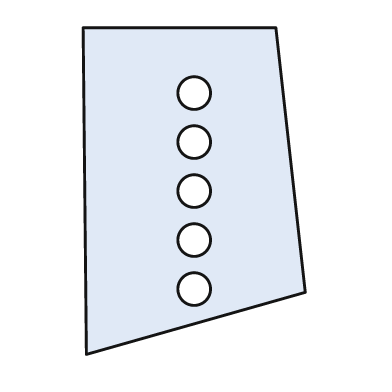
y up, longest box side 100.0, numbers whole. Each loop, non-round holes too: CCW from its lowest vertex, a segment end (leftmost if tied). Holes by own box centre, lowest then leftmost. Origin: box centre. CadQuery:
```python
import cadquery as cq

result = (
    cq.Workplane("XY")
    .moveTo(-33.0, -50.0)
    .lineTo(34.0, -31.0)
    .lineTo(25.0, 50.0)
    .lineTo(-34.0, 50.0)
    .close()
    .moveTo(0.0, -30.0)
    .circle(5.0)
    .moveTo(0.0, -15.0)
    .circle(5.0)
    .moveTo(0.0, 0.0)
    .circle(5.0)
    .moveTo(0.0, 15.0)
    .circle(5.0)
    .moveTo(0.0, 30.0)
    .circle(5.0)
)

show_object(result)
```